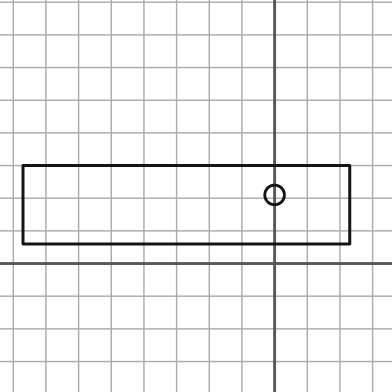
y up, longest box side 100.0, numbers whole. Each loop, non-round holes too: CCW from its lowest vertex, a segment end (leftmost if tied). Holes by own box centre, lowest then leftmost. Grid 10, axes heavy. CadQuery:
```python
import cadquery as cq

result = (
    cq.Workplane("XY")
    .moveTo(-77.0, 6.0)
    .lineTo(23.0, 6.0)
    .lineTo(23.0, 30.0)
    .lineTo(-77.0, 30.0)
    .close()
    .moveTo(0.0, 21.0)
    .circle(3.0)
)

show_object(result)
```